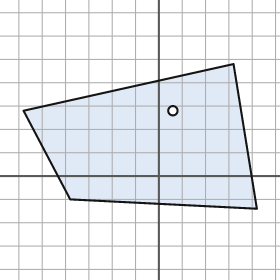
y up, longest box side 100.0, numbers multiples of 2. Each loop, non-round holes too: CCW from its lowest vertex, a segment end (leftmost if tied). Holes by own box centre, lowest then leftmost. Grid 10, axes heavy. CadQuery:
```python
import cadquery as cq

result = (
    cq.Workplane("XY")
    .moveTo(42.0, -14.0)
    .lineTo(32.0, 48.0)
    .lineTo(-58.0, 28.0)
    .lineTo(-38.0, -10.0)
    .close()
    .moveTo(6.0, 28.0)
    .circle(2.0)
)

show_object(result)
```